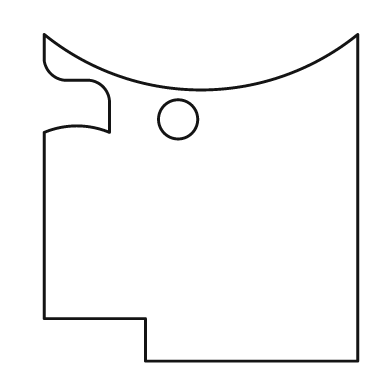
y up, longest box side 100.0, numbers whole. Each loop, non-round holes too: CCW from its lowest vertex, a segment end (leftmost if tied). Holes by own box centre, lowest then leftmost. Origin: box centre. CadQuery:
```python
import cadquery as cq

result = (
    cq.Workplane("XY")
    .moveTo(-17.0, -50.0)
    .lineTo(48.0, -50.0)
    .lineTo(48.0, 50.0)
    .threePointArc((0.0, 33.0), (-48.0, 50.0))
    .lineTo(-48.0, 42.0)
    .threePointArc((-46.0, 38.0), (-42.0, 36.0))
    .lineTo(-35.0, 36.0)
    .threePointArc((-30.0, 34.0), (-28.0, 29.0))
    .lineTo(-28.0, 20.0)
    .threePointArc((-38.0, 22.0), (-48.0, 20.0))
    .lineTo(-48.0, -37.0)
    .lineTo(-17.0, -37.0)
    .close()
    .moveTo(-7.0, 24.0)
    .circle(6.0)
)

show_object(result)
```